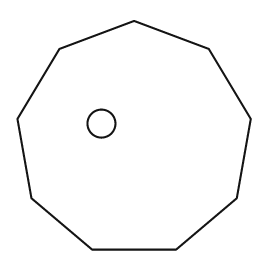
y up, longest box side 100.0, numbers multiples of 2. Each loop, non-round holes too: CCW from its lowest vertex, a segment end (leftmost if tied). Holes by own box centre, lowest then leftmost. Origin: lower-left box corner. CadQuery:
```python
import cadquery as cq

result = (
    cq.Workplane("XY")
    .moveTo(32.0, 0.0)
    .lineTo(68.0, 0.0)
    .lineTo(94.0, 22.0)
    .lineTo(100.0, 56.0)
    .lineTo(82.0, 86.0)
    .lineTo(50.0, 98.0)
    .lineTo(18.0, 86.0)
    .lineTo(0.0, 56.0)
    .lineTo(6.0, 22.0)
    .close()
    .moveTo(36.0, 54.0)
    .circle(6.0)
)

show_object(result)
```